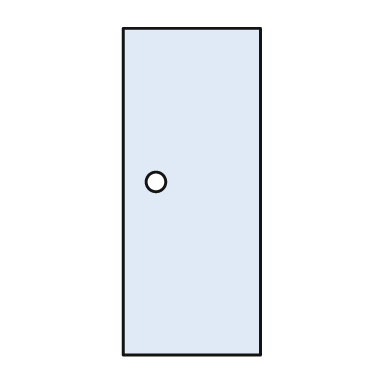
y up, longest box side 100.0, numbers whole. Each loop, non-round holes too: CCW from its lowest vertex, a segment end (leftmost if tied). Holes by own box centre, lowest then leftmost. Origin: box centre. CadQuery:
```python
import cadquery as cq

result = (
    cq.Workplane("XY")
    .moveTo(-21.0, -50.0)
    .lineTo(21.0, -50.0)
    .lineTo(21.0, 50.0)
    .lineTo(-21.0, 50.0)
    .close()
    .moveTo(-11.0, 3.0)
    .circle(3.0)
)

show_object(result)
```